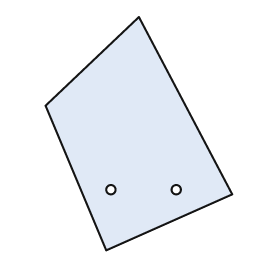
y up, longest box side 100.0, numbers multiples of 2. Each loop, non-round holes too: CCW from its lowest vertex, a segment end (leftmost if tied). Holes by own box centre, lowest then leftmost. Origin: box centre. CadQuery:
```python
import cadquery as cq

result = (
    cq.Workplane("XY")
    .moveTo(-14.0, -50.0)
    .lineTo(40.0, -26.0)
    .lineTo(0.0, 50.0)
    .lineTo(-40.0, 12.0)
    .close()
    .moveTo(-12.0, -24.0)
    .circle(2.0)
    .moveTo(16.0, -24.0)
    .circle(2.0)
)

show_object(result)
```